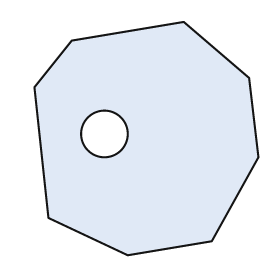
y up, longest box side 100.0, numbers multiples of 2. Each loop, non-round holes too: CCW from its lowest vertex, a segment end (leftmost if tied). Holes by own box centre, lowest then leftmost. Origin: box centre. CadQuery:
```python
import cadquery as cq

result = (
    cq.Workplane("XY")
    .moveTo(-8.0, -50.0)
    .lineTo(28.0, -44.0)
    .lineTo(48.0, -8.0)
    .lineTo(44.0, 26.0)
    .lineTo(16.0, 50.0)
    .lineTo(-32.0, 42.0)
    .lineTo(-48.0, 22.0)
    .lineTo(-42.0, -34.0)
    .close()
    .moveTo(-18.0, 2.0)
    .circle(10.0)
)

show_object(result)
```